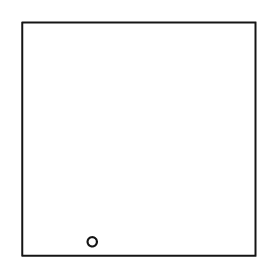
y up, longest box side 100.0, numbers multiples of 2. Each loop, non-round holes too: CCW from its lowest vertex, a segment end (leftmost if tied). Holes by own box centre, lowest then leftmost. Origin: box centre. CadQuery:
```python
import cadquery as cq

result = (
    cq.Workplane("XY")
    .moveTo(-50.0, -50.0)
    .lineTo(50.0, -50.0)
    .lineTo(50.0, 50.0)
    .lineTo(-50.0, 50.0)
    .close()
    .moveTo(-20.0, -44.0)
    .circle(2.0)
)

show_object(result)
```